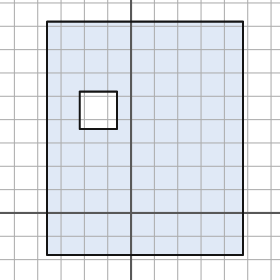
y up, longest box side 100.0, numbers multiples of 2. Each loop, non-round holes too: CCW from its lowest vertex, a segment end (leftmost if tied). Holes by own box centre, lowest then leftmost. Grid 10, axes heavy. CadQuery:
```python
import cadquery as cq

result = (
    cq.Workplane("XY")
    .moveTo(-36.0, -18.0)
    .lineTo(48.0, -18.0)
    .lineTo(48.0, 82.0)
    .lineTo(-36.0, 82.0)
    .close()
    .moveTo(-22.0, 36.0)
    .lineTo(-6.0, 36.0)
    .lineTo(-6.0, 52.0)
    .lineTo(-22.0, 52.0)
    .close()
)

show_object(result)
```